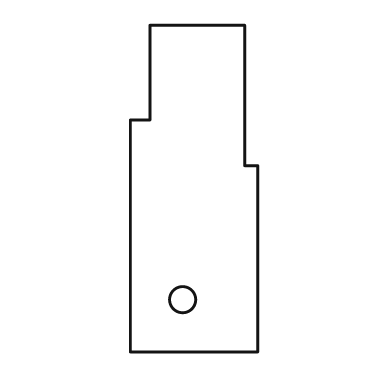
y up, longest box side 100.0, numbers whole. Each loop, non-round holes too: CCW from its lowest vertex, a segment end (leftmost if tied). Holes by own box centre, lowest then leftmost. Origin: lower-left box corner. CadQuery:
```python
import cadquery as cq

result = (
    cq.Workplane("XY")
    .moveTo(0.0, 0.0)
    .lineTo(39.0, 0.0)
    .lineTo(39.0, 57.0)
    .lineTo(35.0, 57.0)
    .lineTo(35.0, 100.0)
    .lineTo(6.0, 100.0)
    .lineTo(6.0, 71.0)
    .lineTo(0.0, 71.0)
    .close()
    .moveTo(16.0, 16.0)
    .circle(4.0)
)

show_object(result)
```